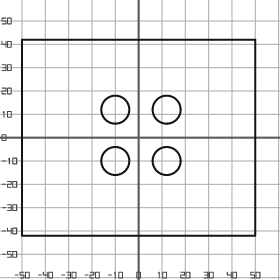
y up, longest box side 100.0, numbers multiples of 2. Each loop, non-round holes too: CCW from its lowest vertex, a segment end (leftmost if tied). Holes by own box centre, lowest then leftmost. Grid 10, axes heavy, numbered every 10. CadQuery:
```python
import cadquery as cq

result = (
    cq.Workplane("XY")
    .moveTo(-50.0, -42.0)
    .lineTo(50.0, -42.0)
    .lineTo(50.0, 42.0)
    .lineTo(-50.0, 42.0)
    .close()
    .moveTo(-10.0, -10.0)
    .circle(6.0)
    .moveTo(12.0, -10.0)
    .circle(6.0)
    .moveTo(-10.0, 12.0)
    .circle(6.0)
    .moveTo(12.0, 12.0)
    .circle(6.0)
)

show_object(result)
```